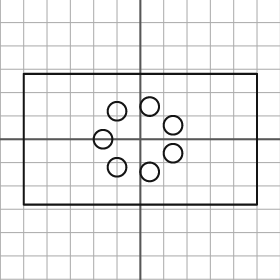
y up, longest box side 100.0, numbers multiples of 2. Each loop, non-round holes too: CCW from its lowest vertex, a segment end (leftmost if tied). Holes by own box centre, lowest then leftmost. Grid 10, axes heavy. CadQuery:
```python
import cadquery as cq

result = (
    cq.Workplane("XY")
    .moveTo(-50.0, -28.0)
    .lineTo(50.0, -28.0)
    .lineTo(50.0, 28.0)
    .lineTo(-50.0, 28.0)
    .close()
    .moveTo(4.0, -14.0)
    .circle(4.0)
    .moveTo(-10.0, -12.0)
    .circle(4.0)
    .moveTo(14.0, -6.0)
    .circle(4.0)
    .moveTo(-16.0, 0.0)
    .circle(4.0)
    .moveTo(14.0, 6.0)
    .circle(4.0)
    .moveTo(-10.0, 12.0)
    .circle(4.0)
    .moveTo(4.0, 14.0)
    .circle(4.0)
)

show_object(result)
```